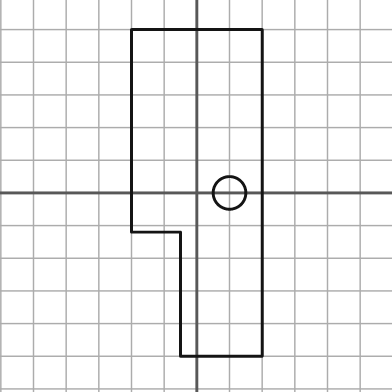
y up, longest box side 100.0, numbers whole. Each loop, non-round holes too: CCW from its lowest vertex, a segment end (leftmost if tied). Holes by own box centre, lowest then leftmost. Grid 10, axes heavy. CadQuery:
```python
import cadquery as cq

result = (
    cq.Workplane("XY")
    .moveTo(-5.0, -50.0)
    .lineTo(20.0, -50.0)
    .lineTo(20.0, 50.0)
    .lineTo(-20.0, 50.0)
    .lineTo(-20.0, -12.0)
    .lineTo(-5.0, -12.0)
    .close()
    .moveTo(10.0, 0.0)
    .circle(5.0)
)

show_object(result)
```